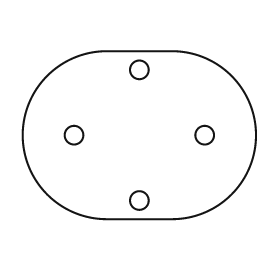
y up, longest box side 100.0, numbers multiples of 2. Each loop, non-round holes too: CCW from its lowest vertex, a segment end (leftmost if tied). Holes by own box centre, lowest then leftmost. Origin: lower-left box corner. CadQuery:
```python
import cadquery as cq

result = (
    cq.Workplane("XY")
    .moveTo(36.0, 0.0)
    .lineTo(64.0, 0.0)
    .threePointArc((100.0, 36.0), (64.0, 72.0))
    .lineTo(36.0, 72.0)
    .threePointArc((0.0, 36.0), (36.0, 0.0))
    .close()
    .moveTo(50.0, 8.0)
    .circle(4.0)
    .moveTo(22.0, 36.0)
    .circle(4.0)
    .moveTo(78.0, 36.0)
    .circle(4.0)
    .moveTo(50.0, 64.0)
    .circle(4.0)
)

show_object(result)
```